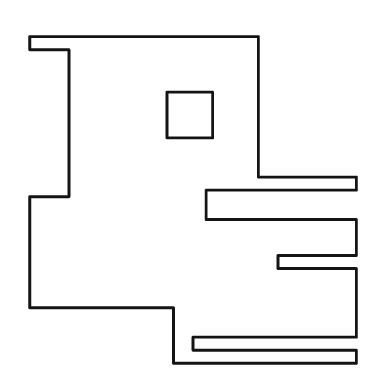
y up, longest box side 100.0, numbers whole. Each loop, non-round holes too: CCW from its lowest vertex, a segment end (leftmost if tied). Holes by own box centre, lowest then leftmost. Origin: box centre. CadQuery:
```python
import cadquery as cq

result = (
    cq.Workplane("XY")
    .moveTo(-6.0, -50.0)
    .lineTo(50.0, -50.0)
    .lineTo(50.0, -46.0)
    .lineTo(0.0, -46.0)
    .lineTo(0.0, -42.0)
    .lineTo(50.0, -42.0)
    .lineTo(50.0, -21.0)
    .lineTo(26.0, -21.0)
    .lineTo(26.0, -17.0)
    .lineTo(50.0, -17.0)
    .lineTo(50.0, -6.0)
    .lineTo(4.0, -6.0)
    .lineTo(4.0, 3.0)
    .lineTo(50.0, 3.0)
    .lineTo(50.0, 7.0)
    .lineTo(20.0, 7.0)
    .lineTo(20.0, 50.0)
    .lineTo(-50.0, 50.0)
    .lineTo(-50.0, 46.0)
    .lineTo(-38.0, 46.0)
    .lineTo(-38.0, 1.0)
    .lineTo(-50.0, 1.0)
    .lineTo(-50.0, -33.0)
    .lineTo(-6.0, -33.0)
    .close()
    .moveTo(-8.0, 19.0)
    .lineTo(6.0, 19.0)
    .lineTo(6.0, 33.0)
    .lineTo(-8.0, 33.0)
    .close()
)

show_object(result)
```